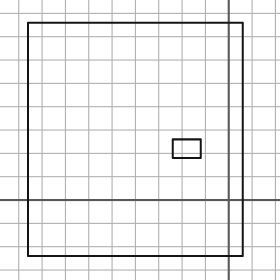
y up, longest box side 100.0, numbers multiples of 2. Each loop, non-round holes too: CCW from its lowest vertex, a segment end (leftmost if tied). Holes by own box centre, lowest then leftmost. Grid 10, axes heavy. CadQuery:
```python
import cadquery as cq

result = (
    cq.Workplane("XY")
    .moveTo(-86.0, -24.0)
    .lineTo(6.0, -24.0)
    .lineTo(6.0, 76.0)
    .lineTo(-86.0, 76.0)
    .close()
    .moveTo(-24.0, 18.0)
    .lineTo(-12.0, 18.0)
    .lineTo(-12.0, 26.0)
    .lineTo(-24.0, 26.0)
    .close()
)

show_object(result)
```